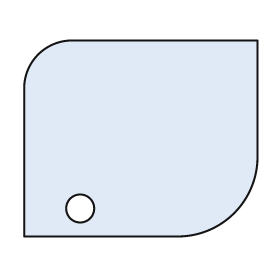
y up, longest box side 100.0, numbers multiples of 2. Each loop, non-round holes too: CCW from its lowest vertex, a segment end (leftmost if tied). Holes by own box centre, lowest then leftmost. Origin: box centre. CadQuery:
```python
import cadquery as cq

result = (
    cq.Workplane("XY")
    .moveTo(-50.0, -42.0)
    .lineTo(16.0, -42.0)
    .threePointArc((40.0, -32.0), (50.0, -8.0))
    .lineTo(50.0, 42.0)
    .lineTo(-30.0, 42.0)
    .threePointArc((-44.0, 36.0), (-50.0, 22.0))
    .close()
    .moveTo(-26.0, -30.0)
    .circle(6.0)
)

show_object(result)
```